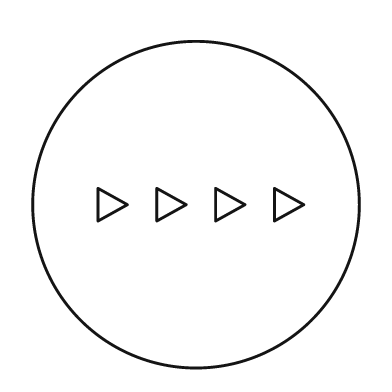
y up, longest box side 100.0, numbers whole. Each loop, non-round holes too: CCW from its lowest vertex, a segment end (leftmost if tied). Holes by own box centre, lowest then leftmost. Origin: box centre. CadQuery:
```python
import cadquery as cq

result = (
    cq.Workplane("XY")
    .moveTo(0.0, 0.0)
    .circle(50.0)
    .moveTo(-30.0, -5.0)
    .lineTo(-21.0, 0.0)
    .lineTo(-30.0, 5.0)
    .close()
    .moveTo(-12.0, -5.0)
    .lineTo(-3.0, 0.0)
    .lineTo(-12.0, 5.0)
    .close()
    .moveTo(6.0, -5.0)
    .lineTo(15.0, 0.0)
    .lineTo(6.0, 5.0)
    .close()
    .moveTo(24.0, -5.0)
    .lineTo(33.0, 0.0)
    .lineTo(24.0, 5.0)
    .close()
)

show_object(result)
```